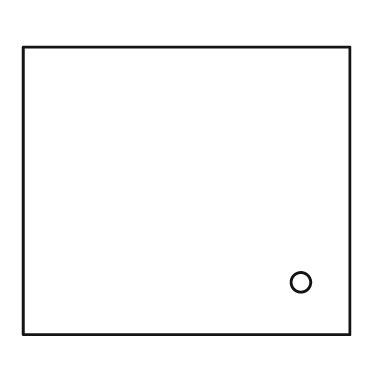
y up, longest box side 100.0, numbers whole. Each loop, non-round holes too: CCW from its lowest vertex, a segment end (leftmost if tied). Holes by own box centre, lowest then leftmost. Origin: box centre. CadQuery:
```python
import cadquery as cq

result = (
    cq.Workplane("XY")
    .moveTo(-50.0, -44.0)
    .lineTo(50.0, -44.0)
    .lineTo(50.0, 44.0)
    .lineTo(-50.0, 44.0)
    .close()
    .moveTo(35.0, -28.0)
    .circle(3.0)
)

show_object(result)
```